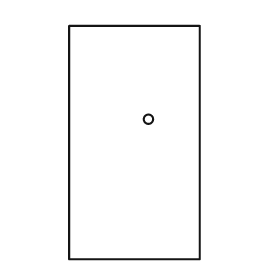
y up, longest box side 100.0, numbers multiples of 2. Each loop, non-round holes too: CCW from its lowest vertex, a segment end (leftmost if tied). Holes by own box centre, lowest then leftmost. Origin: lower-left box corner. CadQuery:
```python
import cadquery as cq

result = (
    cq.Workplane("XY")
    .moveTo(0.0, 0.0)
    .lineTo(56.0, 0.0)
    .lineTo(56.0, 100.0)
    .lineTo(0.0, 100.0)
    .close()
    .moveTo(34.0, 60.0)
    .circle(2.0)
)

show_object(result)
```